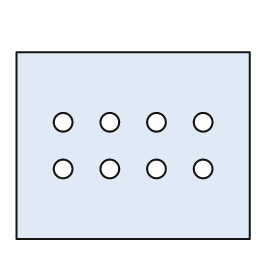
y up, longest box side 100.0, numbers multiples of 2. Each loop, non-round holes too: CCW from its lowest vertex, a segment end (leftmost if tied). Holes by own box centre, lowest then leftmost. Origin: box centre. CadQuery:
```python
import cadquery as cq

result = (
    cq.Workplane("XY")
    .moveTo(-50.0, -40.0)
    .lineTo(50.0, -40.0)
    .lineTo(50.0, 40.0)
    .lineTo(-50.0, 40.0)
    .close()
    .moveTo(-30.0, -10.0)
    .circle(4.0)
    .moveTo(-10.0, -10.0)
    .circle(4.0)
    .moveTo(10.0, -10.0)
    .circle(4.0)
    .moveTo(30.0, -10.0)
    .circle(4.0)
    .moveTo(-30.0, 10.0)
    .circle(4.0)
    .moveTo(-10.0, 10.0)
    .circle(4.0)
    .moveTo(10.0, 10.0)
    .circle(4.0)
    .moveTo(30.0, 10.0)
    .circle(4.0)
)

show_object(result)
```